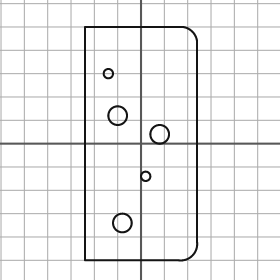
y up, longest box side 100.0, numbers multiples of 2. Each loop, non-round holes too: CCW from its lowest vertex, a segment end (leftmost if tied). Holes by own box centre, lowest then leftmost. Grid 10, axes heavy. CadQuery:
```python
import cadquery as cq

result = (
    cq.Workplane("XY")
    .moveTo(-24.0, -50.0)
    .lineTo(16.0, -50.0)
    .threePointArc((22.0, -48.0), (24.0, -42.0))
    .lineTo(24.0, 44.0)
    .threePointArc((22.0, 48.0), (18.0, 50.0))
    .lineTo(-24.0, 50.0)
    .close()
    .moveTo(-8.0, -34.0)
    .circle(4.0)
    .moveTo(2.0, -14.0)
    .circle(2.0)
    .moveTo(8.0, 4.0)
    .circle(4.0)
    .moveTo(-10.0, 12.0)
    .circle(4.0)
    .moveTo(-14.0, 30.0)
    .circle(2.0)
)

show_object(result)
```